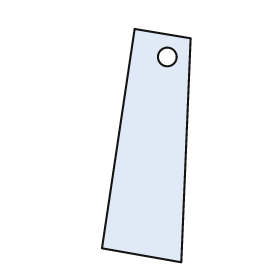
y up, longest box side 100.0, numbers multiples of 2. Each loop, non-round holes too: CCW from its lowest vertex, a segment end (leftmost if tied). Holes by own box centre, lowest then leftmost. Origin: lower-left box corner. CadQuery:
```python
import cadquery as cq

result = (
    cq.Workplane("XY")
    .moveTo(34.0, 0.0)
    .lineTo(38.0, 96.0)
    .lineTo(14.0, 100.0)
    .lineTo(0.0, 6.0)
    .close()
    .moveTo(28.0, 88.0)
    .circle(4.0)
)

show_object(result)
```